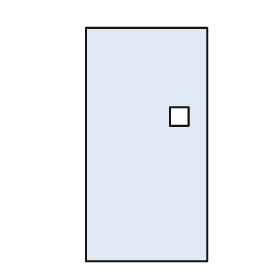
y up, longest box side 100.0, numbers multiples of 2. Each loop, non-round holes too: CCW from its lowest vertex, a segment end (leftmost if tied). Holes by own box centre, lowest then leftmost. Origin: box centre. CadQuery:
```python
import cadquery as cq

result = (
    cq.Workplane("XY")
    .moveTo(-26.0, -50.0)
    .lineTo(26.0, -50.0)
    .lineTo(26.0, 50.0)
    .lineTo(-26.0, 50.0)
    .close()
    .moveTo(10.0, 8.0)
    .lineTo(18.0, 8.0)
    .lineTo(18.0, 16.0)
    .lineTo(10.0, 16.0)
    .close()
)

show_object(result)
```